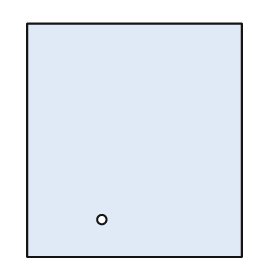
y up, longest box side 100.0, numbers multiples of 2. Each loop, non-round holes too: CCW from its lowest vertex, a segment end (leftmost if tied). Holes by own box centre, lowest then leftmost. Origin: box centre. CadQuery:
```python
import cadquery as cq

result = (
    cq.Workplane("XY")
    .moveTo(-46.0, -50.0)
    .lineTo(46.0, -50.0)
    .lineTo(46.0, 50.0)
    .lineTo(-46.0, 50.0)
    .close()
    .moveTo(-14.0, -34.0)
    .circle(2.0)
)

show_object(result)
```